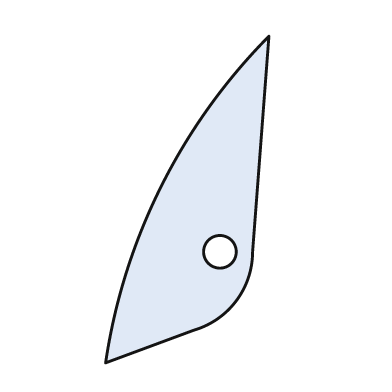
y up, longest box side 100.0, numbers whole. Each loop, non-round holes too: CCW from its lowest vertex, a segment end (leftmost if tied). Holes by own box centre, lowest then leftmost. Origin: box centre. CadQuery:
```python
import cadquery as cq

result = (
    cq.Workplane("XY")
    .moveTo(-25.0, -50.0)
    .lineTo(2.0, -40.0)
    .threePointArc((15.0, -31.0), (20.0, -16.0))
    .lineTo(25.0, 50.0)
    .threePointArc((-8.0, 4.0), (-25.0, -50.0))
    .close()
    .moveTo(10.0, -16.0)
    .circle(5.0)
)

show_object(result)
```